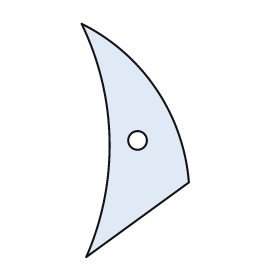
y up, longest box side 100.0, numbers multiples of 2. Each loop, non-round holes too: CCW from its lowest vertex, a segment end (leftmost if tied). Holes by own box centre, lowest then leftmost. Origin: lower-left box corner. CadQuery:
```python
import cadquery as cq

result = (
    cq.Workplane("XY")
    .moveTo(2.0, 0.0)
    .lineTo(46.0, 32.0)
    .threePointArc((32.0, 72.0), (0.0, 100.0))
    .threePointArc((12.0, 50.0), (2.0, 0.0))
    .close()
    .moveTo(24.0, 50.0)
    .circle(4.0)
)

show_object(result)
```